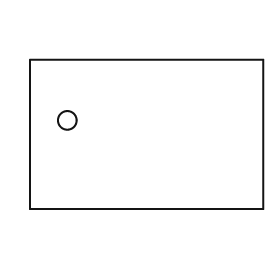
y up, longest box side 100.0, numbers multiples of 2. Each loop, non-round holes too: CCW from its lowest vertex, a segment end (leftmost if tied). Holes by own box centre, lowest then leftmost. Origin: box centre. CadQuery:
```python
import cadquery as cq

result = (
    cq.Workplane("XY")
    .moveTo(-50.0, -32.0)
    .lineTo(50.0, -32.0)
    .lineTo(50.0, 32.0)
    .lineTo(-50.0, 32.0)
    .close()
    .moveTo(-34.0, 6.0)
    .circle(4.0)
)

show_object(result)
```